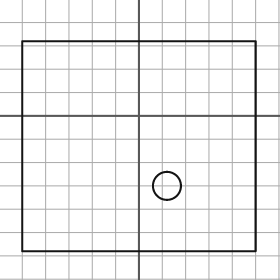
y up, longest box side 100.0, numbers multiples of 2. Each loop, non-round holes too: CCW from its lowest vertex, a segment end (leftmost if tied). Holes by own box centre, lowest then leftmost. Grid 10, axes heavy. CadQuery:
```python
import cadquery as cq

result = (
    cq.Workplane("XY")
    .moveTo(-50.0, -58.0)
    .lineTo(50.0, -58.0)
    .lineTo(50.0, 32.0)
    .lineTo(-50.0, 32.0)
    .close()
    .moveTo(12.0, -30.0)
    .circle(6.0)
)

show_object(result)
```